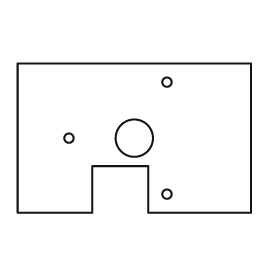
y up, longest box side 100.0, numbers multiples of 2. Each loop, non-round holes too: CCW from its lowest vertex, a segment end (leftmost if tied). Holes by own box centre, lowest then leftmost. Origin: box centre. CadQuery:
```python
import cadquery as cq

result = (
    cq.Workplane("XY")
    .moveTo(-50.0, -32.0)
    .lineTo(-18.0, -32.0)
    .lineTo(-18.0, -12.0)
    .lineTo(6.0, -12.0)
    .lineTo(6.0, -32.0)
    .lineTo(50.0, -32.0)
    .lineTo(50.0, 32.0)
    .lineTo(-50.0, 32.0)
    .close()
    .moveTo(14.0, -24.0)
    .circle(2.0)
    .moveTo(-28.0, 0.0)
    .circle(2.0)
    .moveTo(0.0, 0.0)
    .circle(8.0)
    .moveTo(14.0, 24.0)
    .circle(2.0)
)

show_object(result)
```